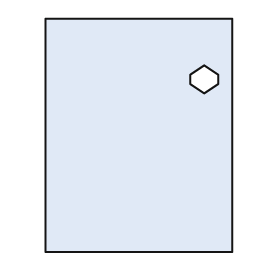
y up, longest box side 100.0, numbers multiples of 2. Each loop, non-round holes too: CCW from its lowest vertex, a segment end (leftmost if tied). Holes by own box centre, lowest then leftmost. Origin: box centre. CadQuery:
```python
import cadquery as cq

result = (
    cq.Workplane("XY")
    .moveTo(-40.0, -50.0)
    .lineTo(40.0, -50.0)
    .lineTo(40.0, 50.0)
    .lineTo(-40.0, 50.0)
    .close()
    .moveTo(28.0, 18.0)
    .lineTo(34.0, 22.0)
    .lineTo(34.0, 26.0)
    .lineTo(28.0, 30.0)
    .lineTo(22.0, 26.0)
    .lineTo(22.0, 22.0)
    .close()
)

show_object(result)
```